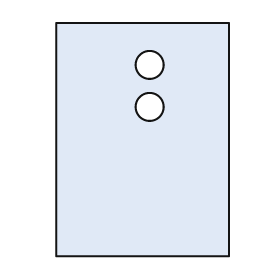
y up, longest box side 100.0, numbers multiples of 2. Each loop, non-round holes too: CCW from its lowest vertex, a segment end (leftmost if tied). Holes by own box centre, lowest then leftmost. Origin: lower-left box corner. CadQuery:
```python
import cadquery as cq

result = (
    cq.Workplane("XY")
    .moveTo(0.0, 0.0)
    .lineTo(74.0, 0.0)
    .lineTo(74.0, 100.0)
    .lineTo(0.0, 100.0)
    .close()
    .moveTo(40.0, 64.0)
    .circle(6.0)
    .moveTo(40.0, 82.0)
    .circle(6.0)
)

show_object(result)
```